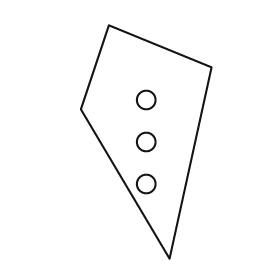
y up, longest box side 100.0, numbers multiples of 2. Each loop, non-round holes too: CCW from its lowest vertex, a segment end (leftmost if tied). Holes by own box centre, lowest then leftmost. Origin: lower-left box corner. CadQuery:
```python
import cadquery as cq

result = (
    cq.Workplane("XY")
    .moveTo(38.0, 0.0)
    .lineTo(56.0, 82.0)
    .lineTo(12.0, 100.0)
    .lineTo(0.0, 64.0)
    .close()
    .moveTo(28.0, 32.0)
    .circle(4.0)
    .moveTo(28.0, 50.0)
    .circle(4.0)
    .moveTo(28.0, 68.0)
    .circle(4.0)
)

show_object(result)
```